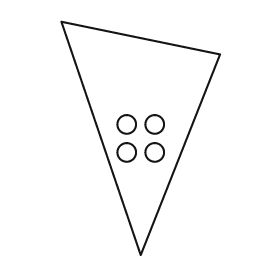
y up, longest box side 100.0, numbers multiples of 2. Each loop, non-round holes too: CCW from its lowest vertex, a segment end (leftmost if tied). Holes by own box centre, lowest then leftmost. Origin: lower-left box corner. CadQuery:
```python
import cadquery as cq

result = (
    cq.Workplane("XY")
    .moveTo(34.0, 0.0)
    .lineTo(68.0, 86.0)
    .lineTo(0.0, 100.0)
    .close()
    .moveTo(28.0, 44.0)
    .circle(4.0)
    .moveTo(40.0, 44.0)
    .circle(4.0)
    .moveTo(28.0, 56.0)
    .circle(4.0)
    .moveTo(40.0, 56.0)
    .circle(4.0)
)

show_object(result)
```